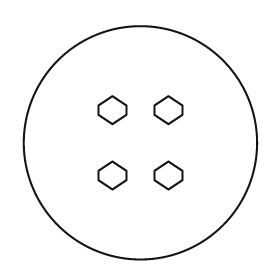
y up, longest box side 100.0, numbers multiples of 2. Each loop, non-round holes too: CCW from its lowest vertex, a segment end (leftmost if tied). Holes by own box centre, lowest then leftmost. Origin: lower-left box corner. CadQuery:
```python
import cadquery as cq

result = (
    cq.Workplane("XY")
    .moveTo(50.0, 50.0)
    .circle(50.0)
    .moveTo(38.0, 30.0)
    .lineTo(44.0, 34.0)
    .lineTo(44.0, 38.0)
    .lineTo(38.0, 42.0)
    .lineTo(32.0, 38.0)
    .lineTo(32.0, 34.0)
    .close()
    .moveTo(62.0, 30.0)
    .lineTo(68.0, 34.0)
    .lineTo(68.0, 38.0)
    .lineTo(62.0, 42.0)
    .lineTo(56.0, 38.0)
    .lineTo(56.0, 34.0)
    .close()
    .moveTo(38.0, 58.0)
    .lineTo(44.0, 62.0)
    .lineTo(44.0, 66.0)
    .lineTo(38.0, 70.0)
    .lineTo(32.0, 66.0)
    .lineTo(32.0, 62.0)
    .close()
    .moveTo(62.0, 58.0)
    .lineTo(68.0, 62.0)
    .lineTo(68.0, 66.0)
    .lineTo(62.0, 70.0)
    .lineTo(56.0, 66.0)
    .lineTo(56.0, 62.0)
    .close()
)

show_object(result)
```